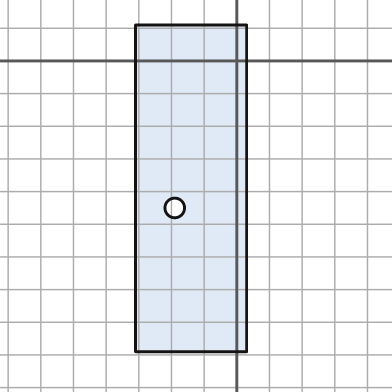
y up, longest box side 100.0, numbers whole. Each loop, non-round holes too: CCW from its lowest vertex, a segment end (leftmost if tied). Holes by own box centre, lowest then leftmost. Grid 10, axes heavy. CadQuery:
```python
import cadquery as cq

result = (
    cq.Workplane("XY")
    .moveTo(-31.0, -89.0)
    .lineTo(3.0, -89.0)
    .lineTo(3.0, 11.0)
    .lineTo(-31.0, 11.0)
    .close()
    .moveTo(-19.0, -45.0)
    .circle(3.0)
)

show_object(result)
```